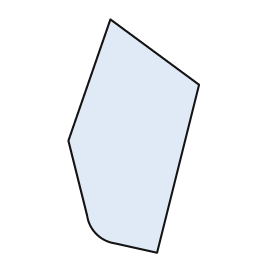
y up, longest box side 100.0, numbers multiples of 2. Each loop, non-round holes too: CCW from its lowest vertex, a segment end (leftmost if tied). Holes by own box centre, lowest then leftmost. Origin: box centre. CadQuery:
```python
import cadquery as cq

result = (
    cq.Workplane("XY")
    .moveTo(10.0, -50.0)
    .lineTo(28.0, 22.0)
    .lineTo(-10.0, 50.0)
    .lineTo(-28.0, -2.0)
    .lineTo(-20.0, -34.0)
    .threePointArc((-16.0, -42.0), (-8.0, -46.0))
    .close()
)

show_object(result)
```